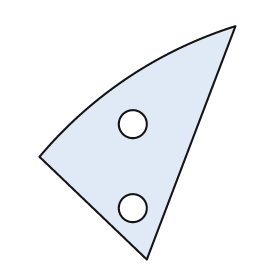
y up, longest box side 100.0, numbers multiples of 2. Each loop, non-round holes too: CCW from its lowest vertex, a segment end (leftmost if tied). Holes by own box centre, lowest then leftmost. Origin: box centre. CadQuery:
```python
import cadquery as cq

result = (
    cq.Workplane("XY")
    .moveTo(4.0, -50.0)
    .lineTo(42.0, 50.0)
    .threePointArc((-4.0, 28.0), (-42.0, -6.0))
    .close()
    .moveTo(-2.0, -28.0)
    .circle(6.0)
    .moveTo(-2.0, 8.0)
    .circle(6.0)
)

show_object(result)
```